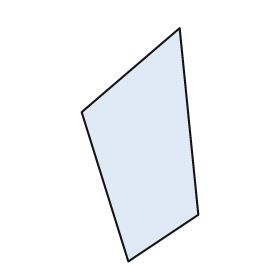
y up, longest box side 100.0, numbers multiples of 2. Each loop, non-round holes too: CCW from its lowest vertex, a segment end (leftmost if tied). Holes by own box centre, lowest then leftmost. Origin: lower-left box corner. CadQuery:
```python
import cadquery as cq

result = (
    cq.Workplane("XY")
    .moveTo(20.0, 0.0)
    .lineTo(50.0, 20.0)
    .lineTo(42.0, 100.0)
    .lineTo(0.0, 64.0)
    .close()
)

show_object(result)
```